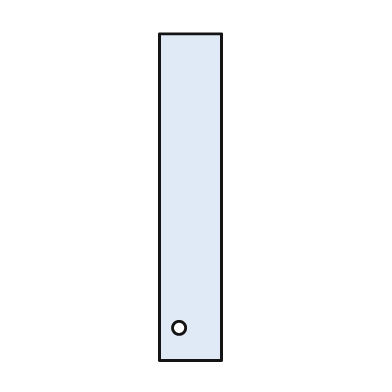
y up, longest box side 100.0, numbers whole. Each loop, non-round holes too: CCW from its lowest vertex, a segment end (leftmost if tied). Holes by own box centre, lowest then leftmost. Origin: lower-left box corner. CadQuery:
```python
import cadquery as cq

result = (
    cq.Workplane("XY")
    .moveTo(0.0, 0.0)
    .lineTo(19.0, 0.0)
    .lineTo(19.0, 100.0)
    .lineTo(0.0, 100.0)
    .close()
    .moveTo(6.0, 10.0)
    .circle(2.0)
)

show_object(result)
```